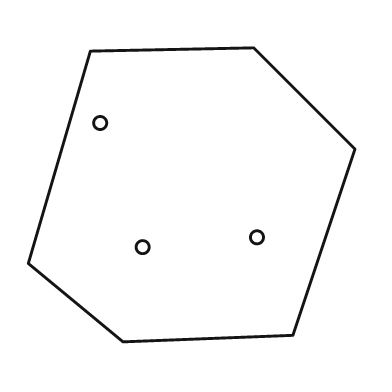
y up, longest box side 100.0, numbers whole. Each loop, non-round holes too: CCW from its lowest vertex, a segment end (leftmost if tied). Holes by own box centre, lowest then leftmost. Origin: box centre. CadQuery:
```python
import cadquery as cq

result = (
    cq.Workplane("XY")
    .moveTo(-21.0, -45.0)
    .lineTo(31.0, -43.0)
    .lineTo(50.0, 14.0)
    .lineTo(19.0, 45.0)
    .lineTo(-31.0, 44.0)
    .lineTo(-50.0, -21.0)
    .close()
    .moveTo(-15.0, -16.0)
    .circle(2.0)
    .moveTo(20.0, -13.0)
    .circle(2.0)
    .moveTo(-28.0, 22.0)
    .circle(2.0)
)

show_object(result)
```